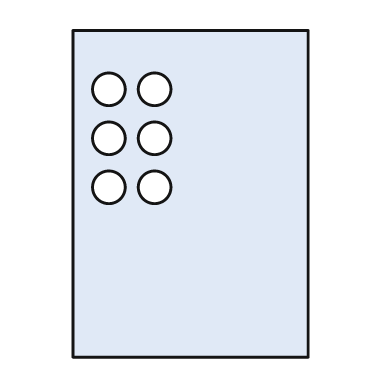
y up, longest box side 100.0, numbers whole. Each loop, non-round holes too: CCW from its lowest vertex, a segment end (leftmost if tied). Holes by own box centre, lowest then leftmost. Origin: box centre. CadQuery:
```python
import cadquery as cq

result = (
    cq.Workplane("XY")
    .moveTo(-36.0, -50.0)
    .lineTo(36.0, -50.0)
    .lineTo(36.0, 50.0)
    .lineTo(-36.0, 50.0)
    .close()
    .moveTo(-25.0, 2.0)
    .circle(5.0)
    .moveTo(-11.0, 2.0)
    .circle(5.0)
    .moveTo(-25.0, 17.0)
    .circle(5.0)
    .moveTo(-11.0, 17.0)
    .circle(5.0)
    .moveTo(-25.0, 32.0)
    .circle(5.0)
    .moveTo(-11.0, 32.0)
    .circle(5.0)
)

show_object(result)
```